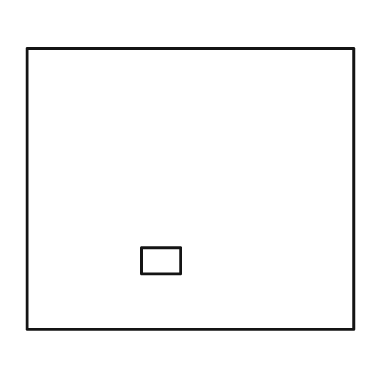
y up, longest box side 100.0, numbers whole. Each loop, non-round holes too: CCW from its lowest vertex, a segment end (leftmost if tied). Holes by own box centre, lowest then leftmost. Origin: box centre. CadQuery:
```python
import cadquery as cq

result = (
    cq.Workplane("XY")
    .moveTo(-50.0, -43.0)
    .lineTo(50.0, -43.0)
    .lineTo(50.0, 43.0)
    .lineTo(-50.0, 43.0)
    .close()
    .moveTo(-15.0, -26.0)
    .lineTo(-3.0, -26.0)
    .lineTo(-3.0, -18.0)
    .lineTo(-15.0, -18.0)
    .close()
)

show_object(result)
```